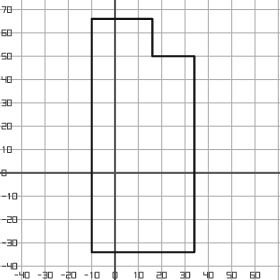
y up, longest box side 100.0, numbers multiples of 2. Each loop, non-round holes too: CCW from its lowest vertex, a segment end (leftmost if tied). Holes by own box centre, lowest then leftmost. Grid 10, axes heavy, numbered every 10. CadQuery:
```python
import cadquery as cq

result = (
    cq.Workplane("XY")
    .moveTo(-10.0, -34.0)
    .lineTo(34.0, -34.0)
    .lineTo(34.0, 50.0)
    .lineTo(16.0, 50.0)
    .lineTo(16.0, 66.0)
    .lineTo(-10.0, 66.0)
    .close()
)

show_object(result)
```